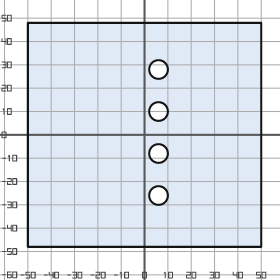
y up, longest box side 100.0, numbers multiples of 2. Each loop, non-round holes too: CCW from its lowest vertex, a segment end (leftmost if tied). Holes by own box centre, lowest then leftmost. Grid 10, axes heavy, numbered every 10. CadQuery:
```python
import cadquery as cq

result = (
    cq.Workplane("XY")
    .moveTo(-50.0, -48.0)
    .lineTo(50.0, -48.0)
    .lineTo(50.0, 48.0)
    .lineTo(-50.0, 48.0)
    .close()
    .moveTo(6.0, -26.0)
    .circle(4.0)
    .moveTo(6.0, -8.0)
    .circle(4.0)
    .moveTo(6.0, 10.0)
    .circle(4.0)
    .moveTo(6.0, 28.0)
    .circle(4.0)
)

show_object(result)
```